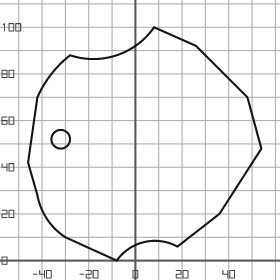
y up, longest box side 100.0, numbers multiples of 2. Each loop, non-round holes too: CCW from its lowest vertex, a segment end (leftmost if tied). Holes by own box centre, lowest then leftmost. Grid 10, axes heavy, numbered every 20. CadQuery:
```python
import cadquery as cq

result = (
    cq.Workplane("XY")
    .moveTo(-8.0, 0.0)
    .threePointArc((4.0, 8.0), (18.0, 6.0))
    .lineTo(36.0, 20.0)
    .lineTo(54.0, 48.0)
    .lineTo(48.0, 70.0)
    .lineTo(26.0, 92.0)
    .lineTo(8.0, 100.0)
    .threePointArc((-8.0, 88.0), (-28.0, 88.0))
    .threePointArc((-36.0, 80.0), (-42.0, 70.0))
    .lineTo(-46.0, 42.0)
    .lineTo(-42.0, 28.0)
    .threePointArc((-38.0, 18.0), (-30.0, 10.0))
    .close()
    .moveTo(-32.0, 52.0)
    .circle(4.0)
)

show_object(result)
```